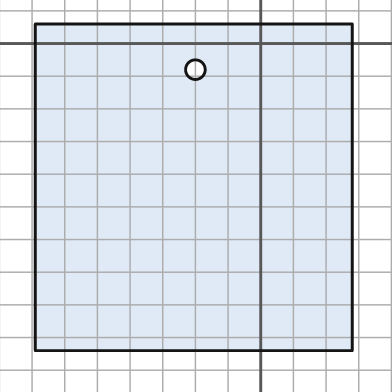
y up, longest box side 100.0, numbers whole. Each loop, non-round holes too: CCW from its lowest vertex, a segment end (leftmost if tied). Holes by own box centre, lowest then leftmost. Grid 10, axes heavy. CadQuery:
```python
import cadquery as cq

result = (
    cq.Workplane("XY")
    .moveTo(-69.0, -94.0)
    .lineTo(28.0, -94.0)
    .lineTo(28.0, 6.0)
    .lineTo(-69.0, 6.0)
    .close()
    .moveTo(-20.0, -8.0)
    .circle(3.0)
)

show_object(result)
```